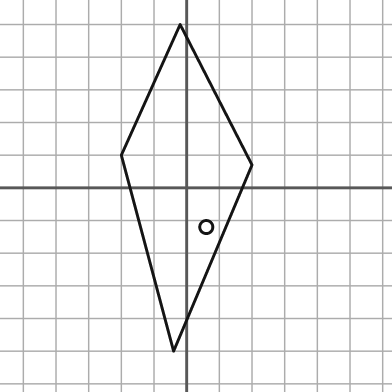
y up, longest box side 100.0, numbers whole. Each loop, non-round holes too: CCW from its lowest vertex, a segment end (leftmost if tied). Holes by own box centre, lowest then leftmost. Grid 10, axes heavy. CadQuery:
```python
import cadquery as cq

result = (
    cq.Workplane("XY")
    .moveTo(-4.0, -50.0)
    .lineTo(20.0, 7.0)
    .lineTo(-2.0, 50.0)
    .lineTo(-20.0, 10.0)
    .close()
    .moveTo(6.0, -12.0)
    .circle(2.0)
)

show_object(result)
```